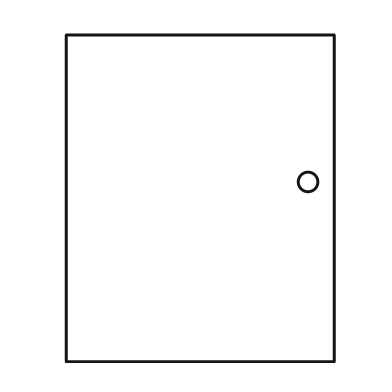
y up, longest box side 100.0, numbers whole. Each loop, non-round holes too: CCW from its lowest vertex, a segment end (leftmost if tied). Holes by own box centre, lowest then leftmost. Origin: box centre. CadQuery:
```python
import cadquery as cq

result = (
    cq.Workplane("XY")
    .moveTo(-41.0, -50.0)
    .lineTo(41.0, -50.0)
    .lineTo(41.0, 50.0)
    .lineTo(-41.0, 50.0)
    .close()
    .moveTo(33.0, 5.0)
    .circle(3.0)
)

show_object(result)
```